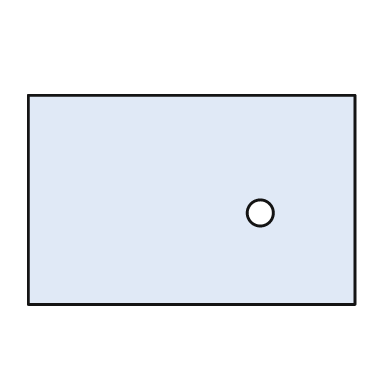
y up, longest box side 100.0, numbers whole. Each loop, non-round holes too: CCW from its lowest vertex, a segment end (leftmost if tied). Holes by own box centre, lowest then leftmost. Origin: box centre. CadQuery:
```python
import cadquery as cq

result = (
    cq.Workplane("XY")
    .moveTo(-50.0, -32.0)
    .lineTo(50.0, -32.0)
    .lineTo(50.0, 32.0)
    .lineTo(-50.0, 32.0)
    .close()
    .moveTo(21.0, -4.0)
    .circle(4.0)
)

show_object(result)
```